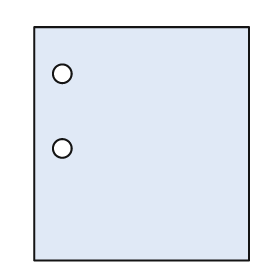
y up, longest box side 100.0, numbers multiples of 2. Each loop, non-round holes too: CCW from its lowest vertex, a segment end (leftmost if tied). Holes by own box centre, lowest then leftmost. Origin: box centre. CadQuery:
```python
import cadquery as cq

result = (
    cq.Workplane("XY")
    .moveTo(-46.0, -50.0)
    .lineTo(46.0, -50.0)
    .lineTo(46.0, 50.0)
    .lineTo(-46.0, 50.0)
    .close()
    .moveTo(-34.0, -2.0)
    .circle(4.0)
    .moveTo(-34.0, 30.0)
    .circle(4.0)
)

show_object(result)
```